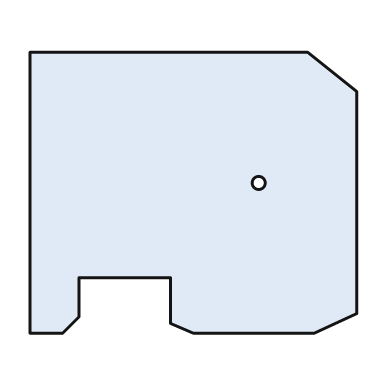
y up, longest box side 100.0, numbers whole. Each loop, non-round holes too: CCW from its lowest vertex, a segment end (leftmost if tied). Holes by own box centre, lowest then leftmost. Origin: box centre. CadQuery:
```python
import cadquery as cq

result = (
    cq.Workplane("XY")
    .moveTo(-50.0, -43.0)
    .lineTo(-40.0, -43.0)
    .lineTo(-35.0, -38.0)
    .lineTo(-35.0, -26.0)
    .lineTo(-7.0, -26.0)
    .lineTo(-7.0, -40.0)
    .lineTo(0.0, -43.0)
    .lineTo(37.0, -43.0)
    .lineTo(50.0, -37.0)
    .lineTo(50.0, 31.0)
    .lineTo(35.0, 43.0)
    .lineTo(-50.0, 43.0)
    .close()
    .moveTo(20.0, 3.0)
    .circle(2.0)
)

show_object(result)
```